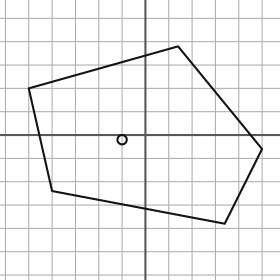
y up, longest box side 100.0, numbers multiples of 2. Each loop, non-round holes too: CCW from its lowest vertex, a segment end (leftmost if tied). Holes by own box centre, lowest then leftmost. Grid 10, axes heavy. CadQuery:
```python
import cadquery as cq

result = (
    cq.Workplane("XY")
    .moveTo(34.0, -38.0)
    .lineTo(50.0, -6.0)
    .lineTo(14.0, 38.0)
    .lineTo(-50.0, 20.0)
    .lineTo(-40.0, -24.0)
    .close()
    .moveTo(-10.0, -2.0)
    .circle(2.0)
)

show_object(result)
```